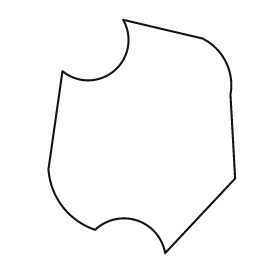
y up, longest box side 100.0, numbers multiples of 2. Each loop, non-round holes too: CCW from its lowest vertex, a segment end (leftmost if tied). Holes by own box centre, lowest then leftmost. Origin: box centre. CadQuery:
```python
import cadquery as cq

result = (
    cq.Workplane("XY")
    .moveTo(10.0, -50.0)
    .lineTo(40.0, -18.0)
    .lineTo(38.0, 18.0)
    .threePointArc((36.0, 32.0), (26.0, 42.0))
    .lineTo(-8.0, 50.0)
    .threePointArc((-12.0, 28.0), (-34.0, 28.0))
    .lineTo(-40.0, -14.0)
    .threePointArc((-34.0, -30.0), (-20.0, -40.0))
    .threePointArc((-2.0, -36.0), (10.0, -50.0))
    .close()
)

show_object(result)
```